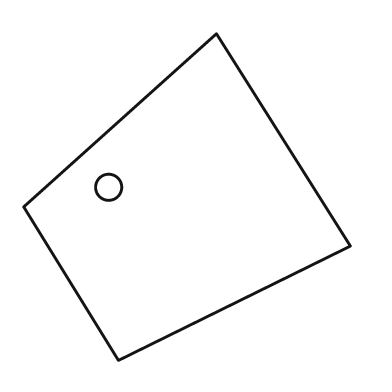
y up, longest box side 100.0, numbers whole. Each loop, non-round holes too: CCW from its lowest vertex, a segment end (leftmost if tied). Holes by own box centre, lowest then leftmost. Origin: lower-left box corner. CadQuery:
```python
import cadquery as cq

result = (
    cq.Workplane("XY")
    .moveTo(29.0, 0.0)
    .lineTo(100.0, 35.0)
    .lineTo(59.0, 100.0)
    .lineTo(0.0, 47.0)
    .close()
    .moveTo(26.0, 53.0)
    .circle(4.0)
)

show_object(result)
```